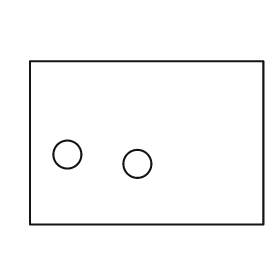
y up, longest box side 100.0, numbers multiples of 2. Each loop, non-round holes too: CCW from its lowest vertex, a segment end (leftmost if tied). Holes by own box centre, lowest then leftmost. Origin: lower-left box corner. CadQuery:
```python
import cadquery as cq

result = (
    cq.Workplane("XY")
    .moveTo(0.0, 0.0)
    .lineTo(100.0, 0.0)
    .lineTo(100.0, 70.0)
    .lineTo(0.0, 70.0)
    .close()
    .moveTo(46.0, 26.0)
    .circle(6.0)
    .moveTo(16.0, 30.0)
    .circle(6.0)
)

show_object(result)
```